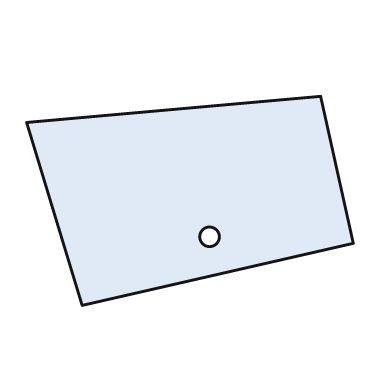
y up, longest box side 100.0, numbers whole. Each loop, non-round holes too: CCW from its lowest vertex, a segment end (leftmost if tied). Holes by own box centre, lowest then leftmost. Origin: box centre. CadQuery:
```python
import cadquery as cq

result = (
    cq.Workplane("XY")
    .moveTo(-33.0, -32.0)
    .lineTo(50.0, -13.0)
    .lineTo(40.0, 32.0)
    .lineTo(-50.0, 24.0)
    .close()
    .moveTo(6.0, -11.0)
    .circle(3.0)
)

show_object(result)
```